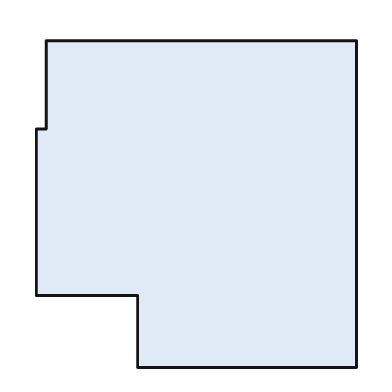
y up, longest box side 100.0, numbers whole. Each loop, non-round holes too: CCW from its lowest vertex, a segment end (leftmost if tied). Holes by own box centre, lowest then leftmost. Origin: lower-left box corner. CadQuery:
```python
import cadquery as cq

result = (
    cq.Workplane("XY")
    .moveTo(31.0, 0.0)
    .lineTo(98.0, 0.0)
    .lineTo(98.0, 100.0)
    .lineTo(3.0, 100.0)
    .lineTo(3.0, 73.0)
    .lineTo(0.0, 73.0)
    .lineTo(0.0, 22.0)
    .lineTo(31.0, 22.0)
    .close()
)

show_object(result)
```